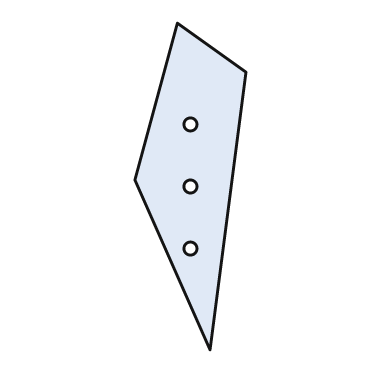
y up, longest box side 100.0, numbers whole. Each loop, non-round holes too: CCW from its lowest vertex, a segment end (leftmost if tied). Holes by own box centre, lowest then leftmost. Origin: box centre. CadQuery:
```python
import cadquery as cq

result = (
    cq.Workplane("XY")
    .moveTo(6.0, -50.0)
    .lineTo(17.0, 35.0)
    .lineTo(-4.0, 50.0)
    .lineTo(-17.0, 2.0)
    .close()
    .moveTo(0.0, -19.0)
    .circle(2.0)
    .moveTo(0.0, 0.0)
    .circle(2.0)
    .moveTo(0.0, 19.0)
    .circle(2.0)
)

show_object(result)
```